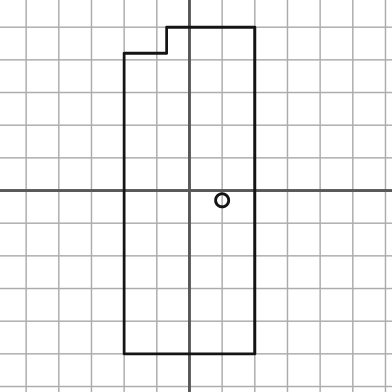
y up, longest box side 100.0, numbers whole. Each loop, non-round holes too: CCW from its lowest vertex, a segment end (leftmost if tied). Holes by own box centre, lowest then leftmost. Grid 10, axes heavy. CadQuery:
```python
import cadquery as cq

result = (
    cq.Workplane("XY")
    .moveTo(-20.0, -50.0)
    .lineTo(20.0, -50.0)
    .lineTo(20.0, 50.0)
    .lineTo(-7.0, 50.0)
    .lineTo(-7.0, 42.0)
    .lineTo(-20.0, 42.0)
    .close()
    .moveTo(10.0, -3.0)
    .circle(2.0)
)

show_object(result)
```